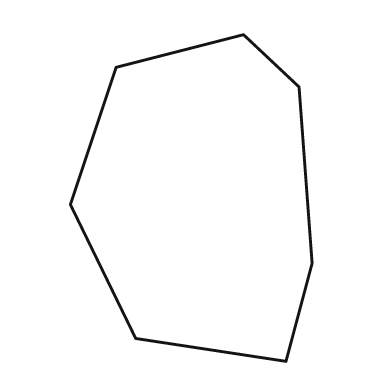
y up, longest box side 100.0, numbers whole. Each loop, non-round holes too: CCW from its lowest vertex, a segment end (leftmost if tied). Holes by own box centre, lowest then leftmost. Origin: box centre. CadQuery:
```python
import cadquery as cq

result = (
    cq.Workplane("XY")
    .moveTo(29.0, -50.0)
    .lineTo(37.0, -20.0)
    .lineTo(33.0, 34.0)
    .lineTo(16.0, 50.0)
    .lineTo(-23.0, 40.0)
    .lineTo(-37.0, -2.0)
    .lineTo(-17.0, -43.0)
    .close()
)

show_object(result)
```